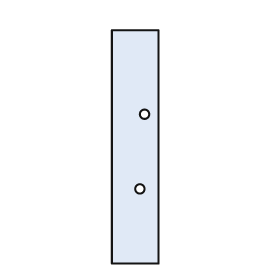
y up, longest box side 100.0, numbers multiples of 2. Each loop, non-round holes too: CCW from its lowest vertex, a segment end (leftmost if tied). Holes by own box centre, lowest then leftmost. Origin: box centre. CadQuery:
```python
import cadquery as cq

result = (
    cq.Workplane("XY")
    .moveTo(-10.0, -50.0)
    .lineTo(10.0, -50.0)
    .lineTo(10.0, 50.0)
    .lineTo(-10.0, 50.0)
    .close()
    .moveTo(2.0, -18.0)
    .circle(2.0)
    .moveTo(4.0, 14.0)
    .circle(2.0)
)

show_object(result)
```